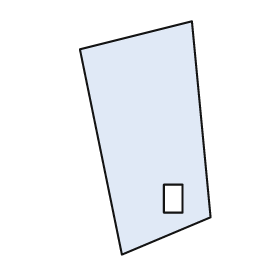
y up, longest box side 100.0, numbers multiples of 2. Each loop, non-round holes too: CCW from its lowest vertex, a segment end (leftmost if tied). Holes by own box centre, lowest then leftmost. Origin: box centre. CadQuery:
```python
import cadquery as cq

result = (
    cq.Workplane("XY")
    .moveTo(-10.0, -50.0)
    .lineTo(28.0, -34.0)
    .lineTo(20.0, 50.0)
    .lineTo(-28.0, 38.0)
    .close()
    .moveTo(8.0, -32.0)
    .lineTo(16.0, -32.0)
    .lineTo(16.0, -20.0)
    .lineTo(8.0, -20.0)
    .close()
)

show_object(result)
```